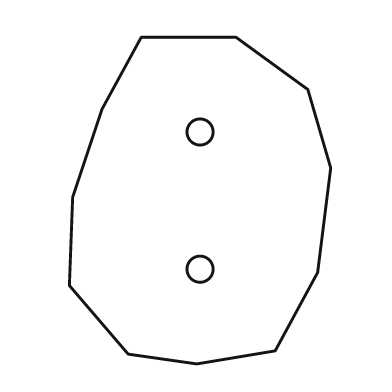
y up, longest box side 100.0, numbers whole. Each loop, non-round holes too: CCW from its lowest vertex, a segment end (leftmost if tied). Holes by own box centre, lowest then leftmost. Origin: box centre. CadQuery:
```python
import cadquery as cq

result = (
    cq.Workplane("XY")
    .moveTo(-1.0, -50.0)
    .lineTo(23.0, -46.0)
    .lineTo(36.0, -22.0)
    .lineTo(40.0, 10.0)
    .lineTo(33.0, 34.0)
    .lineTo(11.0, 50.0)
    .lineTo(-18.0, 50.0)
    .lineTo(-30.0, 28.0)
    .lineTo(-39.0, 1.0)
    .lineTo(-40.0, -26.0)
    .lineTo(-22.0, -47.0)
    .close()
    .moveTo(0.0, -21.0)
    .circle(4.0)
    .moveTo(0.0, 21.0)
    .circle(4.0)
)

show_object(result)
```